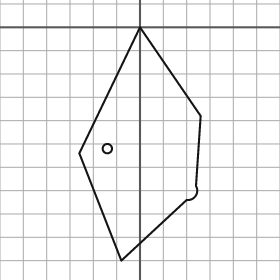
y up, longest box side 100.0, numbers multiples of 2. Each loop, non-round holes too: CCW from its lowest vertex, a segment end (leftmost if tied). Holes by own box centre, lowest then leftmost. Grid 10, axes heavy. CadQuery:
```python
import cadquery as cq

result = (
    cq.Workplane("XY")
    .moveTo(-8.0, -100.0)
    .lineTo(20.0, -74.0)
    .threePointArc((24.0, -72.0), (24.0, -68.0))
    .lineTo(26.0, -38.0)
    .lineTo(0.0, 0.0)
    .lineTo(-26.0, -54.0)
    .close()
    .moveTo(-14.0, -52.0)
    .circle(2.0)
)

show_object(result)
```